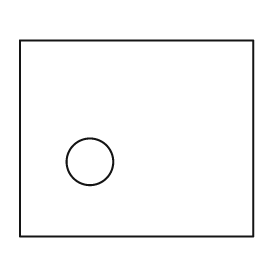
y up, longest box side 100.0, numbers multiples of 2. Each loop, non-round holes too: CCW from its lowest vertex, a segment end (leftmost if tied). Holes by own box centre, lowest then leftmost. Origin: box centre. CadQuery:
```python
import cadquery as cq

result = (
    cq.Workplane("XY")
    .moveTo(-50.0, -42.0)
    .lineTo(50.0, -42.0)
    .lineTo(50.0, 42.0)
    .lineTo(-50.0, 42.0)
    .close()
    .moveTo(-20.0, -10.0)
    .circle(10.0)
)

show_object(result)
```